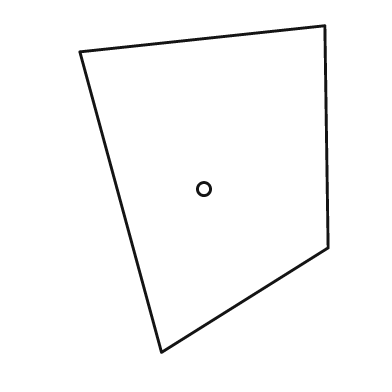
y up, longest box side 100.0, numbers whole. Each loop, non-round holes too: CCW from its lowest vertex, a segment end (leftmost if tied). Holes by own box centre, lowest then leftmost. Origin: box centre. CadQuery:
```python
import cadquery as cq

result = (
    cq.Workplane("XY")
    .moveTo(-13.0, -50.0)
    .lineTo(38.0, -18.0)
    .lineTo(37.0, 50.0)
    .lineTo(-38.0, 42.0)
    .close()
    .moveTo(0.0, 0.0)
    .circle(2.0)
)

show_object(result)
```